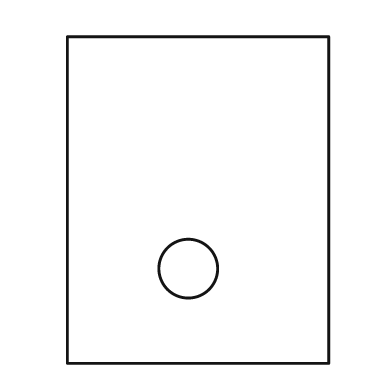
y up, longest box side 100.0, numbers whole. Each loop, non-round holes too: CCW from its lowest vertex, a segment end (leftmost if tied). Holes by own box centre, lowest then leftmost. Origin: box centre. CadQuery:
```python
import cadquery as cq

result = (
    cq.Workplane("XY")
    .moveTo(-40.0, -50.0)
    .lineTo(40.0, -50.0)
    .lineTo(40.0, 50.0)
    .lineTo(-40.0, 50.0)
    .close()
    .moveTo(-3.0, -21.0)
    .circle(9.0)
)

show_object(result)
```